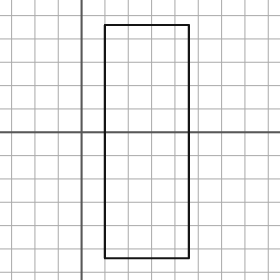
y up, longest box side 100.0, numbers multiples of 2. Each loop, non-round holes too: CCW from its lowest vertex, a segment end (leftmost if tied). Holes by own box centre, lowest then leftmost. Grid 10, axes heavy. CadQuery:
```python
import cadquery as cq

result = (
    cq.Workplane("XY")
    .moveTo(10.0, -54.0)
    .lineTo(46.0, -54.0)
    .lineTo(46.0, 46.0)
    .lineTo(10.0, 46.0)
    .close()
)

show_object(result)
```